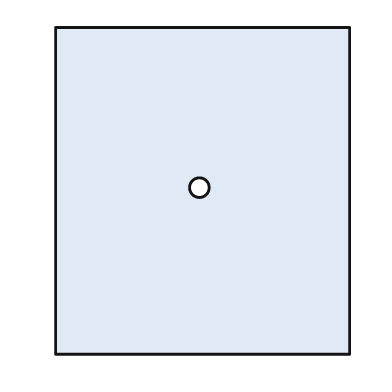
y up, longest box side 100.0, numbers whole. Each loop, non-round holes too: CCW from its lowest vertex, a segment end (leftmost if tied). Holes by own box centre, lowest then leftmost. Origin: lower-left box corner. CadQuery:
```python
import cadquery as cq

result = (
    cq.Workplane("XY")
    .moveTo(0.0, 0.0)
    .lineTo(90.0, 0.0)
    .lineTo(90.0, 100.0)
    .lineTo(0.0, 100.0)
    .close()
    .moveTo(44.0, 51.0)
    .circle(3.0)
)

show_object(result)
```